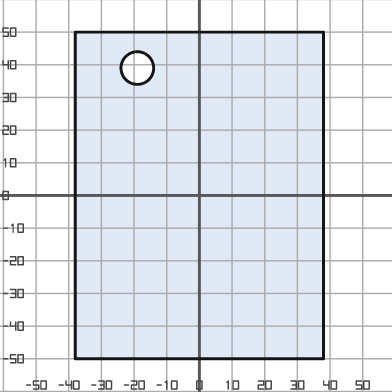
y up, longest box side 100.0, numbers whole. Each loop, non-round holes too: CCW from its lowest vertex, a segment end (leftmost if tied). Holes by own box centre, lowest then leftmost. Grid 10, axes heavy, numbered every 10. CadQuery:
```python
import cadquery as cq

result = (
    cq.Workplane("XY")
    .moveTo(-38.0, -50.0)
    .lineTo(38.0, -50.0)
    .lineTo(38.0, 50.0)
    .lineTo(-38.0, 50.0)
    .close()
    .moveTo(-19.0, 39.0)
    .circle(5.0)
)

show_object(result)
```